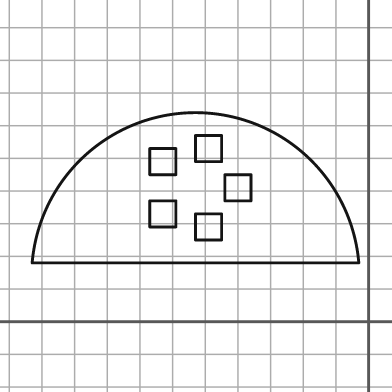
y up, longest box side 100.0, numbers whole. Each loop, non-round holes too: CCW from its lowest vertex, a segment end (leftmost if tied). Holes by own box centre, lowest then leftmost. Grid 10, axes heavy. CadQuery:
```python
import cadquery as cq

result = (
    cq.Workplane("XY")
    .moveTo(-103.0, 18.0)
    .lineTo(-3.0, 18.0)
    .threePointArc((-53.0, 64.0), (-103.0, 18.0))
    .close()
    .moveTo(-53.0, 25.0)
    .lineTo(-45.0, 25.0)
    .lineTo(-45.0, 33.0)
    .lineTo(-53.0, 33.0)
    .close()
    .moveTo(-67.0, 29.0)
    .lineTo(-59.0, 29.0)
    .lineTo(-59.0, 37.0)
    .lineTo(-67.0, 37.0)
    .close()
    .moveTo(-44.0, 37.0)
    .lineTo(-36.0, 37.0)
    .lineTo(-36.0, 45.0)
    .lineTo(-44.0, 45.0)
    .close()
    .moveTo(-67.0, 45.0)
    .lineTo(-59.0, 45.0)
    .lineTo(-59.0, 53.0)
    .lineTo(-67.0, 53.0)
    .close()
    .moveTo(-53.0, 49.0)
    .lineTo(-45.0, 49.0)
    .lineTo(-45.0, 57.0)
    .lineTo(-53.0, 57.0)
    .close()
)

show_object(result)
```